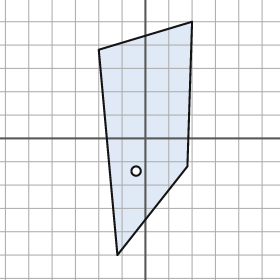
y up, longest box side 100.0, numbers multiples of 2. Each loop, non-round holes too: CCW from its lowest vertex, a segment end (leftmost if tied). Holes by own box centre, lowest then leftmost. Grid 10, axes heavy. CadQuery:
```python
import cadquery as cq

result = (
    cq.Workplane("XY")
    .moveTo(-12.0, -50.0)
    .lineTo(18.0, -12.0)
    .lineTo(20.0, 50.0)
    .lineTo(-20.0, 38.0)
    .close()
    .moveTo(-4.0, -14.0)
    .circle(2.0)
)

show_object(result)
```